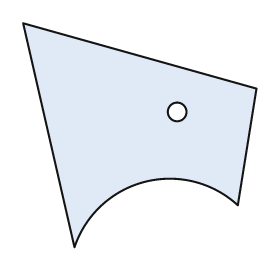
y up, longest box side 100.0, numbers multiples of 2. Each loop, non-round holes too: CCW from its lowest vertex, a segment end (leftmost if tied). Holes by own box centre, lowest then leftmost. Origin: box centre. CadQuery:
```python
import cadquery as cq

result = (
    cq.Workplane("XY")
    .moveTo(-28.0, -48.0)
    .threePointArc((2.0, -20.0), (42.0, -30.0))
    .lineTo(50.0, 20.0)
    .lineTo(-50.0, 48.0)
    .close()
    .moveTo(16.0, 10.0)
    .circle(4.0)
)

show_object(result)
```